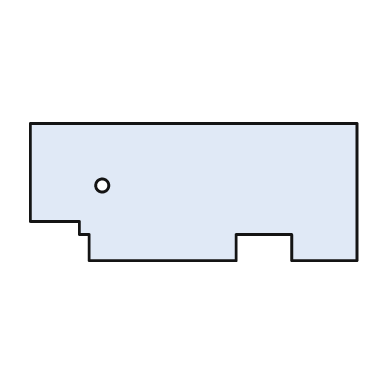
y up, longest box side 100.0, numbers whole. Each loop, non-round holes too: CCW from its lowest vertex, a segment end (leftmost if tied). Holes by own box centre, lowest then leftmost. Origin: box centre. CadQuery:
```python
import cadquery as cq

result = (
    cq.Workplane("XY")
    .moveTo(-32.0, -21.0)
    .lineTo(13.0, -21.0)
    .lineTo(13.0, -13.0)
    .lineTo(30.0, -13.0)
    .lineTo(30.0, -21.0)
    .lineTo(50.0, -21.0)
    .lineTo(50.0, 21.0)
    .lineTo(-50.0, 21.0)
    .lineTo(-50.0, -9.0)
    .lineTo(-35.0, -9.0)
    .lineTo(-35.0, -13.0)
    .lineTo(-32.0, -13.0)
    .close()
    .moveTo(-28.0, 2.0)
    .circle(2.0)
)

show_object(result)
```